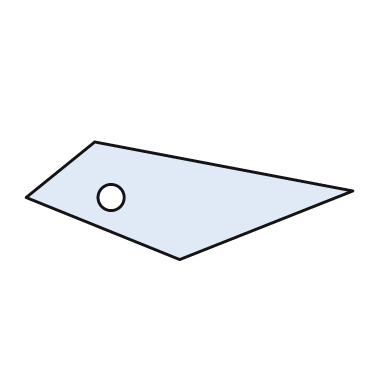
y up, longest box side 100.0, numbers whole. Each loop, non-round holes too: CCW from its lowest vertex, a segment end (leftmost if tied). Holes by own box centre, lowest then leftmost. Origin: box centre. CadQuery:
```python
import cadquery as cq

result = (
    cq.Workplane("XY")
    .moveTo(-3.0, -18.0)
    .lineTo(50.0, 3.0)
    .lineTo(-29.0, 18.0)
    .lineTo(-50.0, 1.0)
    .close()
    .moveTo(-24.0, 1.0)
    .circle(4.0)
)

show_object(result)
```